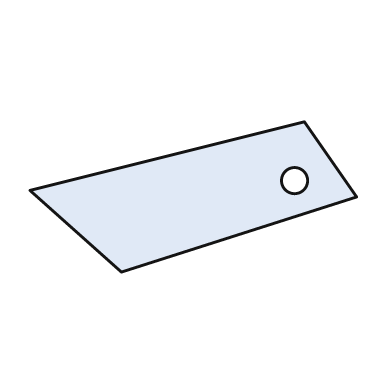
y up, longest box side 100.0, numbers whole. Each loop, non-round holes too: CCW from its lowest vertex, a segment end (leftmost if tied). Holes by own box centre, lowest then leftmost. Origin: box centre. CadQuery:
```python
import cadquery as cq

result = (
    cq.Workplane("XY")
    .moveTo(-22.0, -23.0)
    .lineTo(50.0, 0.0)
    .lineTo(34.0, 23.0)
    .lineTo(-50.0, 2.0)
    .close()
    .moveTo(31.0, 5.0)
    .circle(4.0)
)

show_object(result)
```